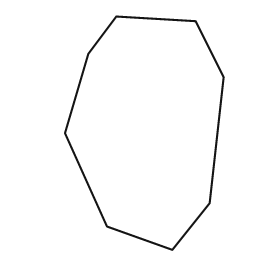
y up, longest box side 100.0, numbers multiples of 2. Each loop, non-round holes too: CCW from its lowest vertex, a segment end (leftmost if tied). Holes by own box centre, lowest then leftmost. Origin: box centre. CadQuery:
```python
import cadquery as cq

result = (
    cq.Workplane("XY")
    .moveTo(12.0, -50.0)
    .lineTo(28.0, -30.0)
    .lineTo(34.0, 24.0)
    .lineTo(22.0, 48.0)
    .lineTo(-12.0, 50.0)
    .lineTo(-24.0, 34.0)
    .lineTo(-34.0, 0.0)
    .lineTo(-16.0, -40.0)
    .close()
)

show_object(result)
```